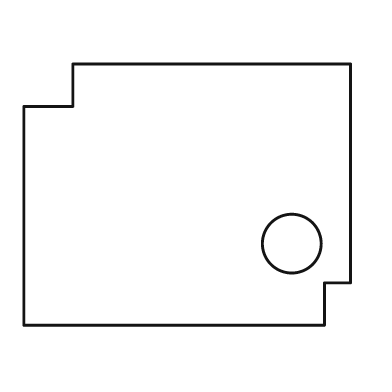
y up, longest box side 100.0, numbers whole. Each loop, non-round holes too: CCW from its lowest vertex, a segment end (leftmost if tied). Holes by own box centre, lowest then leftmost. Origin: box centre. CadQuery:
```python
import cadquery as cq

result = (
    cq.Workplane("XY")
    .moveTo(-50.0, -40.0)
    .lineTo(42.0, -40.0)
    .lineTo(42.0, -27.0)
    .lineTo(50.0, -27.0)
    .lineTo(50.0, 40.0)
    .lineTo(-35.0, 40.0)
    .lineTo(-35.0, 27.0)
    .lineTo(-50.0, 27.0)
    .close()
    .moveTo(32.0, -15.0)
    .circle(9.0)
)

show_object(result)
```